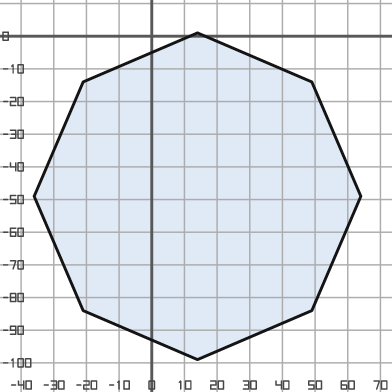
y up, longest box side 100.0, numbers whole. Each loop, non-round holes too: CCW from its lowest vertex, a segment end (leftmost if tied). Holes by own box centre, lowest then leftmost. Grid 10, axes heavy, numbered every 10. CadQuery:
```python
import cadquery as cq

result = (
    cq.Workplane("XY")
    .moveTo(14.0, -99.0)
    .lineTo(49.0, -84.0)
    .lineTo(64.0, -49.0)
    .lineTo(49.0, -14.0)
    .lineTo(14.0, 1.0)
    .lineTo(-21.0, -14.0)
    .lineTo(-36.0, -49.0)
    .lineTo(-21.0, -84.0)
    .close()
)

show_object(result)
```